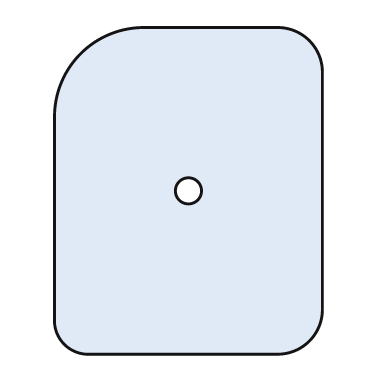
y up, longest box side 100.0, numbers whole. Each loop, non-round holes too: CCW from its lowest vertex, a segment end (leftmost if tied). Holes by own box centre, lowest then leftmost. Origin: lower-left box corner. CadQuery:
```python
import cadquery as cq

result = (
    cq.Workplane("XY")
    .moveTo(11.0, 0.0)
    .lineTo(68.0, 0.0)
    .threePointArc((78.0, 4.0), (82.0, 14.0))
    .lineTo(82.0, 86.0)
    .threePointArc((78.0, 96.0), (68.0, 100.0))
    .lineTo(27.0, 100.0)
    .threePointArc((8.0, 92.0), (0.0, 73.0))
    .lineTo(0.0, 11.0)
    .threePointArc((3.0, 3.0), (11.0, 0.0))
    .close()
    .moveTo(41.0, 50.0)
    .circle(4.0)
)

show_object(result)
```